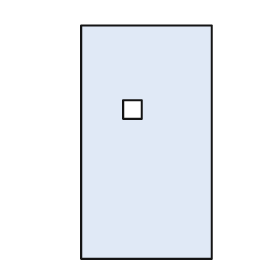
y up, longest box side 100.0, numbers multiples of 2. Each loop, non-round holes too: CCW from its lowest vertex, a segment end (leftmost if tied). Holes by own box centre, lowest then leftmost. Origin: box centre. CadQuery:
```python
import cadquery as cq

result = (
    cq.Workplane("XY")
    .moveTo(-28.0, -50.0)
    .lineTo(28.0, -50.0)
    .lineTo(28.0, 50.0)
    .lineTo(-28.0, 50.0)
    .close()
    .moveTo(-10.0, 10.0)
    .lineTo(-2.0, 10.0)
    .lineTo(-2.0, 18.0)
    .lineTo(-10.0, 18.0)
    .close()
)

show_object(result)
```